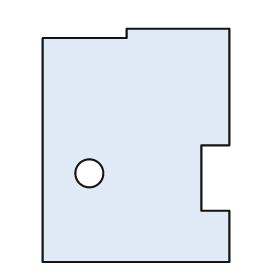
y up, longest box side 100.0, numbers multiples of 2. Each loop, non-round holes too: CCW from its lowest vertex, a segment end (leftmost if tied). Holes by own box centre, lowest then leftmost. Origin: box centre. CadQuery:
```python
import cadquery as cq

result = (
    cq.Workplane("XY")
    .moveTo(-40.0, -50.0)
    .lineTo(40.0, -50.0)
    .lineTo(40.0, -28.0)
    .lineTo(28.0, -28.0)
    .lineTo(28.0, 0.0)
    .lineTo(40.0, 0.0)
    .lineTo(40.0, 50.0)
    .lineTo(-4.0, 50.0)
    .lineTo(-4.0, 46.0)
    .lineTo(-40.0, 46.0)
    .close()
    .moveTo(-20.0, -12.0)
    .circle(6.0)
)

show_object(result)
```